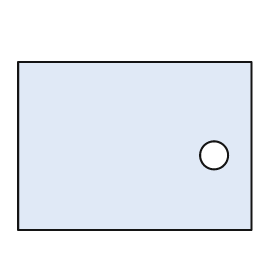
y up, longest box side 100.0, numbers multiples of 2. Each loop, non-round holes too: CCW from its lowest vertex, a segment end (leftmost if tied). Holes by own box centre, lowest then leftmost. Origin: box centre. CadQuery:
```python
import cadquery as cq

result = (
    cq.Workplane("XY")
    .moveTo(-50.0, -36.0)
    .lineTo(50.0, -36.0)
    .lineTo(50.0, 36.0)
    .lineTo(-50.0, 36.0)
    .close()
    .moveTo(34.0, -4.0)
    .circle(6.0)
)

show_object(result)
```